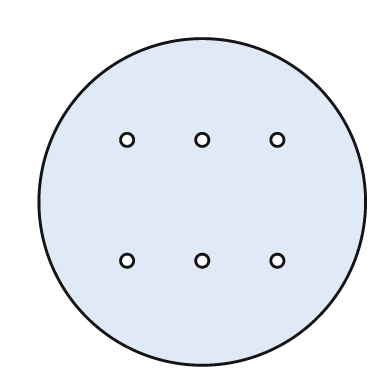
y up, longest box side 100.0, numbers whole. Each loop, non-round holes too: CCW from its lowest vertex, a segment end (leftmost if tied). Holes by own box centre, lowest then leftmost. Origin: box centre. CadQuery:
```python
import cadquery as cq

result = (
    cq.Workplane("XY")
    .moveTo(0.0, 0.0)
    .circle(50.0)
    .moveTo(-23.0, -18.0)
    .circle(2.0)
    .moveTo(0.0, -18.0)
    .circle(2.0)
    .moveTo(23.0, -18.0)
    .circle(2.0)
    .moveTo(-23.0, 19.0)
    .circle(2.0)
    .moveTo(0.0, 19.0)
    .circle(2.0)
    .moveTo(23.0, 19.0)
    .circle(2.0)
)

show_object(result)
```